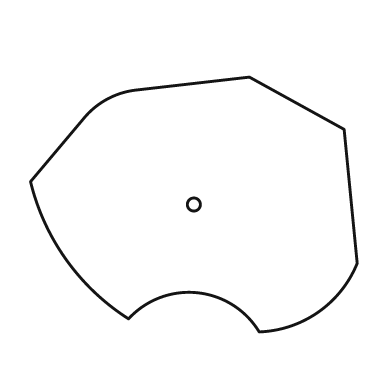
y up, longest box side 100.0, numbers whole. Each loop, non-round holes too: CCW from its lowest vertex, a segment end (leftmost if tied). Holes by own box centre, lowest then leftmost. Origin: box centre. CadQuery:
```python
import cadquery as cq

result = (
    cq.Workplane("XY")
    .moveTo(20.0, -39.0)
    .threePointArc((38.0, -33.0), (50.0, -18.0))
    .lineTo(46.0, 23.0)
    .lineTo(17.0, 39.0)
    .lineTo(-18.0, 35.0)
    .threePointArc((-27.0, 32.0), (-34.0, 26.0))
    .lineTo(-50.0, 7.0)
    .threePointArc((-39.0, -17.0), (-20.0, -35.0))
    .threePointArc((1.0, -27.0), (20.0, -39.0))
    .close()
    .moveTo(0.0, 0.0)
    .circle(2.0)
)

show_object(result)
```